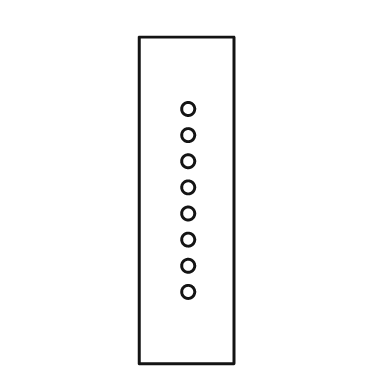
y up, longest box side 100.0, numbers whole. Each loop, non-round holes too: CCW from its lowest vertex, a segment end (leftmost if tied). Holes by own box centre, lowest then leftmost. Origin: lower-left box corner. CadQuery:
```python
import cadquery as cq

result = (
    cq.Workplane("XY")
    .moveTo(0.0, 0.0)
    .lineTo(29.0, 0.0)
    .lineTo(29.0, 100.0)
    .lineTo(0.0, 100.0)
    .close()
    .moveTo(15.0, 22.0)
    .circle(2.0)
    .moveTo(15.0, 30.0)
    .circle(2.0)
    .moveTo(15.0, 38.0)
    .circle(2.0)
    .moveTo(15.0, 46.0)
    .circle(2.0)
    .moveTo(15.0, 54.0)
    .circle(2.0)
    .moveTo(15.0, 62.0)
    .circle(2.0)
    .moveTo(15.0, 70.0)
    .circle(2.0)
    .moveTo(15.0, 78.0)
    .circle(2.0)
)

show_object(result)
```